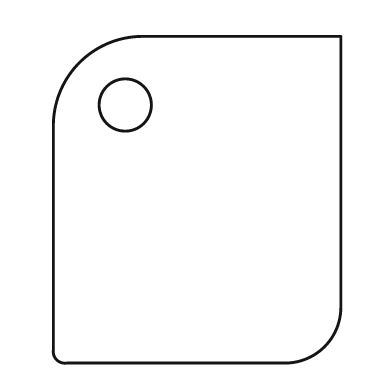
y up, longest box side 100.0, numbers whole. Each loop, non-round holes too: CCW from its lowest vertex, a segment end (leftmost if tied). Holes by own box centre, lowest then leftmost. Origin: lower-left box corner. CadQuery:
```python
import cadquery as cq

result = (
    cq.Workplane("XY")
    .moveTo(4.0, 0.0)
    .lineTo(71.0, 0.0)
    .threePointArc((83.0, 5.0), (88.0, 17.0))
    .lineTo(88.0, 100.0)
    .lineTo(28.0, 100.0)
    .threePointArc((8.0, 92.0), (0.0, 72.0))
    .lineTo(0.0, 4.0)
    .threePointArc((1.0, 1.0), (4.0, 0.0))
    .close()
    .moveTo(22.0, 79.0)
    .circle(8.0)
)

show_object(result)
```